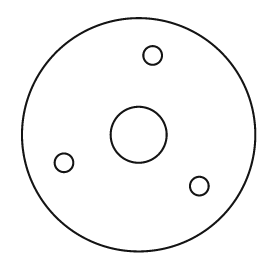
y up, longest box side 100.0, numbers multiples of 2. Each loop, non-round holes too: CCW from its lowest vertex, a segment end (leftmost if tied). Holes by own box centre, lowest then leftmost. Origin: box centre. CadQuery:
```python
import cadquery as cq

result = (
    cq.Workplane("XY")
    .moveTo(0.0, 0.0)
    .circle(50.0)
    .moveTo(26.0, -22.0)
    .circle(4.0)
    .moveTo(-32.0, -12.0)
    .circle(4.0)
    .moveTo(0.0, 0.0)
    .circle(12.0)
    .moveTo(6.0, 34.0)
    .circle(4.0)
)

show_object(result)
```